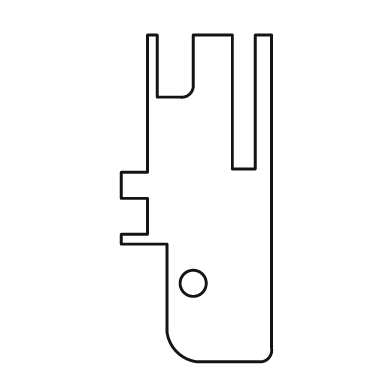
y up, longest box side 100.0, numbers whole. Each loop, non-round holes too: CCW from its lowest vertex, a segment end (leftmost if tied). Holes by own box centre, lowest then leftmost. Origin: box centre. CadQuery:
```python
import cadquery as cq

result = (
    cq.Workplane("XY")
    .moveTo(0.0, -50.0)
    .lineTo(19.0, -50.0)
    .threePointArc((22.0, -49.0), (23.0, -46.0))
    .lineTo(23.0, 50.0)
    .lineTo(18.0, 50.0)
    .lineTo(18.0, 9.0)
    .lineTo(11.0, 9.0)
    .lineTo(11.0, 50.0)
    .lineTo(-1.0, 50.0)
    .lineTo(-1.0, 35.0)
    .threePointArc((-2.0, 32.0), (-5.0, 31.0))
    .lineTo(-12.0, 31.0)
    .lineTo(-12.0, 50.0)
    .lineTo(-15.0, 50.0)
    .lineTo(-15.0, 8.0)
    .lineTo(-23.0, 8.0)
    .lineTo(-23.0, 0.0)
    .lineTo(-15.0, 0.0)
    .lineTo(-15.0, -11.0)
    .lineTo(-23.0, -11.0)
    .lineTo(-23.0, -14.0)
    .lineTo(-9.0, -14.0)
    .lineTo(-9.0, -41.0)
    .threePointArc((-6.0, -47.0), (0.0, -50.0))
    .close()
    .moveTo(-1.0, -26.0)
    .circle(4.0)
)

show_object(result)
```